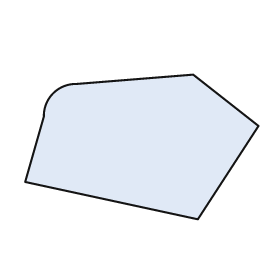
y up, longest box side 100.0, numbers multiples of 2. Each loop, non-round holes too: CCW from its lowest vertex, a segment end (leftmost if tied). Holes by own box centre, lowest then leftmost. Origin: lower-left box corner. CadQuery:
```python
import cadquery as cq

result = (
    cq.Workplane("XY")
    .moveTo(74.0, 0.0)
    .lineTo(100.0, 40.0)
    .lineTo(72.0, 62.0)
    .lineTo(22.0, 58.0)
    .threePointArc((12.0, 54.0), (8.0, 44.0))
    .lineTo(0.0, 16.0)
    .close()
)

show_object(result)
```